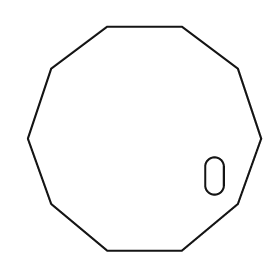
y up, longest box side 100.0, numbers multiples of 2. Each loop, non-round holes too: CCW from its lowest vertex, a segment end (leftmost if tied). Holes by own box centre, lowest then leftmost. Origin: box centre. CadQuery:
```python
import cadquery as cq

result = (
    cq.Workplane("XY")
    .moveTo(-16.0, -48.0)
    .lineTo(16.0, -48.0)
    .lineTo(40.0, -28.0)
    .lineTo(50.0, 0.0)
    .lineTo(40.0, 30.0)
    .lineTo(16.0, 48.0)
    .lineTo(-16.0, 48.0)
    .lineTo(-40.0, 30.0)
    .lineTo(-50.0, 0.0)
    .lineTo(-40.0, -28.0)
    .close()
    .moveTo(26.0, -20.0)
    .threePointArc((30.0, -24.0), (34.0, -20.0))
    .lineTo(34.0, -12.0)
    .threePointArc((30.0, -8.0), (26.0, -12.0))
    .close()
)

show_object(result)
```